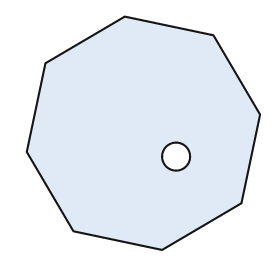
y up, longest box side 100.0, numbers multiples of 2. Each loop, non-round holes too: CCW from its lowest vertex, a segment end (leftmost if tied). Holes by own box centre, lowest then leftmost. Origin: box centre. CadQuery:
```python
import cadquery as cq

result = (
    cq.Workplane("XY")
    .moveTo(8.0, -50.0)
    .lineTo(42.0, -30.0)
    .lineTo(50.0, 8.0)
    .lineTo(30.0, 42.0)
    .lineTo(-8.0, 50.0)
    .lineTo(-42.0, 30.0)
    .lineTo(-50.0, -8.0)
    .lineTo(-30.0, -42.0)
    .close()
    .moveTo(14.0, -10.0)
    .circle(6.0)
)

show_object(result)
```